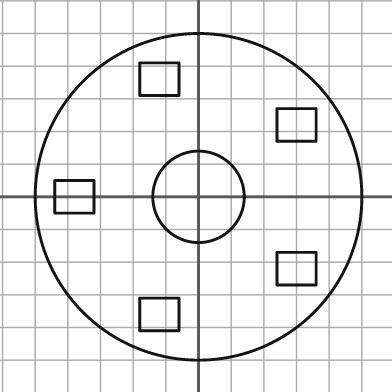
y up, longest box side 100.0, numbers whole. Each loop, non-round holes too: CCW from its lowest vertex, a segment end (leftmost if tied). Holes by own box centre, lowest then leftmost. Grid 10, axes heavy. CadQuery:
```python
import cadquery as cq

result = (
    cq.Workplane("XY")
    .moveTo(0.0, 0.0)
    .circle(50.0)
    .moveTo(-18.0, -41.0)
    .lineTo(-6.0, -41.0)
    .lineTo(-6.0, -31.0)
    .lineTo(-18.0, -31.0)
    .close()
    .moveTo(24.0, -27.0)
    .lineTo(36.0, -27.0)
    .lineTo(36.0, -17.0)
    .lineTo(24.0, -17.0)
    .close()
    .moveTo(-44.0, -5.0)
    .lineTo(-32.0, -5.0)
    .lineTo(-32.0, 5.0)
    .lineTo(-44.0, 5.0)
    .close()
    .moveTo(0.0, 0.0)
    .circle(14.0)
    .moveTo(24.0, 17.0)
    .lineTo(36.0, 17.0)
    .lineTo(36.0, 27.0)
    .lineTo(24.0, 27.0)
    .close()
    .moveTo(-18.0, 31.0)
    .lineTo(-6.0, 31.0)
    .lineTo(-6.0, 41.0)
    .lineTo(-18.0, 41.0)
    .close()
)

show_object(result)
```